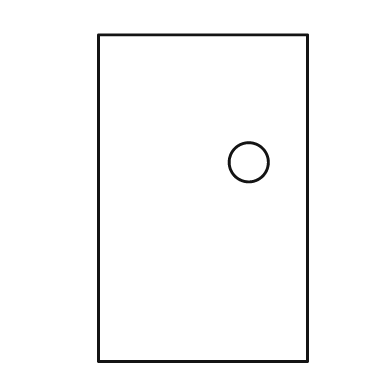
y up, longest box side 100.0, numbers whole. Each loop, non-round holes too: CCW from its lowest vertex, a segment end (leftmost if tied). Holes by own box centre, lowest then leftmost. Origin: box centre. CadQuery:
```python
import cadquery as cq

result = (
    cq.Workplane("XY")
    .moveTo(-32.0, -50.0)
    .lineTo(32.0, -50.0)
    .lineTo(32.0, 50.0)
    .lineTo(-32.0, 50.0)
    .close()
    .moveTo(14.0, 11.0)
    .circle(6.0)
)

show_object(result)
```